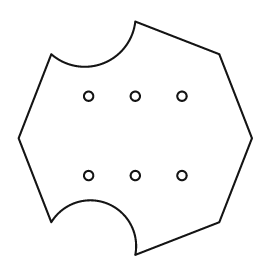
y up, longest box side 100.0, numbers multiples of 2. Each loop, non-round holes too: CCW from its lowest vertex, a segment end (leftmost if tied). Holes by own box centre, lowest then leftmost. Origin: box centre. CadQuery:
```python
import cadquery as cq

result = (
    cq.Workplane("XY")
    .moveTo(0.0, -50.0)
    .lineTo(36.0, -36.0)
    .lineTo(50.0, 0.0)
    .lineTo(36.0, 36.0)
    .lineTo(0.0, 50.0)
    .threePointArc((-14.0, 32.0), (-36.0, 36.0))
    .lineTo(-50.0, 0.0)
    .lineTo(-36.0, -36.0)
    .threePointArc((-12.0, -28.0), (0.0, -50.0))
    .close()
    .moveTo(-20.0, -16.0)
    .circle(2.0)
    .moveTo(0.0, -16.0)
    .circle(2.0)
    .moveTo(20.0, -16.0)
    .circle(2.0)
    .moveTo(-20.0, 18.0)
    .circle(2.0)
    .moveTo(0.0, 18.0)
    .circle(2.0)
    .moveTo(20.0, 18.0)
    .circle(2.0)
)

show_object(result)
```